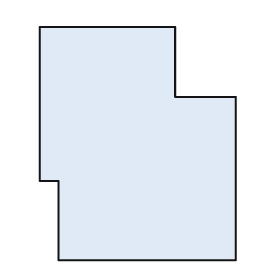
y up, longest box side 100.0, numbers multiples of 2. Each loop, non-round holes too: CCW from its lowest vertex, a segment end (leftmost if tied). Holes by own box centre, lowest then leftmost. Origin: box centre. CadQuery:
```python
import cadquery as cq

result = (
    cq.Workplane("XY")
    .moveTo(-34.0, -50.0)
    .lineTo(42.0, -50.0)
    .lineTo(42.0, 20.0)
    .lineTo(16.0, 20.0)
    .lineTo(16.0, 50.0)
    .lineTo(-42.0, 50.0)
    .lineTo(-42.0, -16.0)
    .lineTo(-34.0, -16.0)
    .close()
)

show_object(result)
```